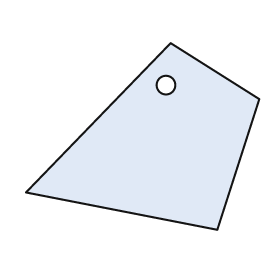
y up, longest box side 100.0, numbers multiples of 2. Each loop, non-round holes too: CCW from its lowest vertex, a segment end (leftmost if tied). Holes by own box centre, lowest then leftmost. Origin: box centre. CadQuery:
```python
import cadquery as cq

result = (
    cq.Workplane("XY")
    .moveTo(32.0, -40.0)
    .lineTo(50.0, 16.0)
    .lineTo(12.0, 40.0)
    .lineTo(-50.0, -24.0)
    .close()
    .moveTo(10.0, 22.0)
    .circle(4.0)
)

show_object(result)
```